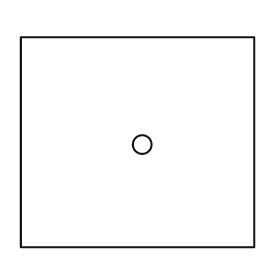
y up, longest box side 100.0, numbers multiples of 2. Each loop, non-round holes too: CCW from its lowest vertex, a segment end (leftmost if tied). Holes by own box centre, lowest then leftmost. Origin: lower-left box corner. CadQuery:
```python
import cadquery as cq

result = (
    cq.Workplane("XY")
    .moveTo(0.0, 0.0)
    .lineTo(100.0, 0.0)
    .lineTo(100.0, 90.0)
    .lineTo(0.0, 90.0)
    .close()
    .moveTo(52.0, 44.0)
    .circle(4.0)
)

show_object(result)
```